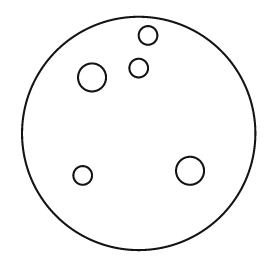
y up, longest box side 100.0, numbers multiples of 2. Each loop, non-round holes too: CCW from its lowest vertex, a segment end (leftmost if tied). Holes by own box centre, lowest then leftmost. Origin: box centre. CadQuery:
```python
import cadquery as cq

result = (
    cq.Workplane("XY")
    .moveTo(0.0, 0.0)
    .circle(50.0)
    .moveTo(-24.0, -18.0)
    .circle(4.0)
    .moveTo(22.0, -16.0)
    .circle(6.0)
    .moveTo(-20.0, 24.0)
    .circle(6.0)
    .moveTo(0.0, 28.0)
    .circle(4.0)
    .moveTo(4.0, 42.0)
    .circle(4.0)
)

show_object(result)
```